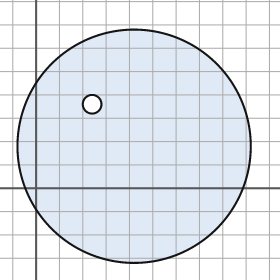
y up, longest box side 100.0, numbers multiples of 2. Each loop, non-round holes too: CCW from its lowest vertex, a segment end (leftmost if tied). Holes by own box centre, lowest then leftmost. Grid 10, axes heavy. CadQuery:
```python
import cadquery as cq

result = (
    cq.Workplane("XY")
    .moveTo(42.0, 18.0)
    .circle(50.0)
    .moveTo(24.0, 36.0)
    .circle(4.0)
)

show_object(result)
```